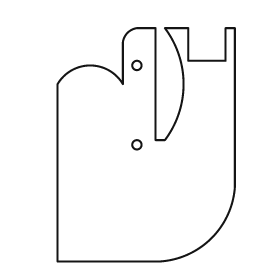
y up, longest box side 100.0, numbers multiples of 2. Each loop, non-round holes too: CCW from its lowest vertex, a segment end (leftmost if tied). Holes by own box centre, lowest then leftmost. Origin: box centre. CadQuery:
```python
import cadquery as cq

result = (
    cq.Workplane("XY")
    .moveTo(-38.0, -50.0)
    .lineTo(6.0, -50.0)
    .threePointArc((28.0, -40.0), (38.0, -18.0))
    .lineTo(38.0, 50.0)
    .lineTo(34.0, 50.0)
    .lineTo(34.0, 36.0)
    .lineTo(18.0, 36.0)
    .lineTo(18.0, 50.0)
    .lineTo(8.0, 50.0)
    .threePointArc((16.0, 26.0), (8.0, 2.0))
    .lineTo(4.0, 2.0)
    .lineTo(4.0, 50.0)
    .lineTo(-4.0, 50.0)
    .threePointArc((-8.0, 48.0), (-10.0, 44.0))
    .lineTo(-10.0, 26.0)
    .threePointArc((-24.0, 34.0), (-38.0, 26.0))
    .close()
    .moveTo(-4.0, 0.0)
    .circle(2.0)
    .moveTo(-4.0, 34.0)
    .circle(2.0)
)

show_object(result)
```